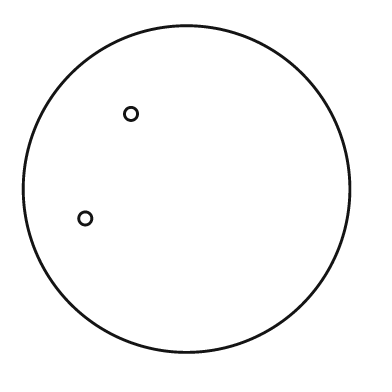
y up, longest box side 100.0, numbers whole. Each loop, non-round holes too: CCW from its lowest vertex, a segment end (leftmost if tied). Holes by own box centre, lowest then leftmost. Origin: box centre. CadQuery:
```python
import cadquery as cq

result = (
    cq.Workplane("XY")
    .moveTo(0.0, 0.0)
    .circle(50.0)
    .moveTo(-31.0, -9.0)
    .circle(2.0)
    .moveTo(-17.0, 23.0)
    .circle(2.0)
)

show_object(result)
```